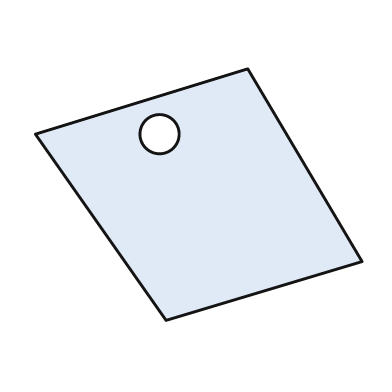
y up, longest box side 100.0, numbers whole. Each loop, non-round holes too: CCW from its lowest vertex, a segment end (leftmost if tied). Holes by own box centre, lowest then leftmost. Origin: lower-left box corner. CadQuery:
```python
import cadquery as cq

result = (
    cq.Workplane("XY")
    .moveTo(40.0, 0.0)
    .lineTo(100.0, 18.0)
    .lineTo(65.0, 77.0)
    .lineTo(0.0, 57.0)
    .close()
    .moveTo(38.0, 57.0)
    .circle(6.0)
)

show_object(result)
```